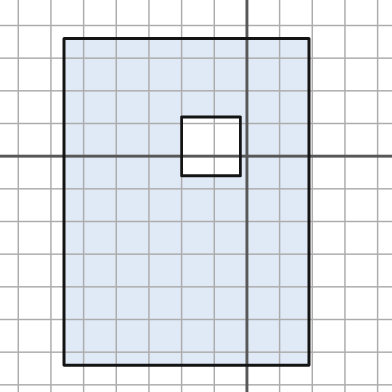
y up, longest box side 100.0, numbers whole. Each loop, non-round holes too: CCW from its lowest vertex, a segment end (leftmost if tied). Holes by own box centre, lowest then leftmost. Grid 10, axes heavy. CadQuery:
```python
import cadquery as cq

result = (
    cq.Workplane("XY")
    .moveTo(-56.0, -64.0)
    .lineTo(19.0, -64.0)
    .lineTo(19.0, 36.0)
    .lineTo(-56.0, 36.0)
    .close()
    .moveTo(-20.0, -6.0)
    .lineTo(-2.0, -6.0)
    .lineTo(-2.0, 12.0)
    .lineTo(-20.0, 12.0)
    .close()
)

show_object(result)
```